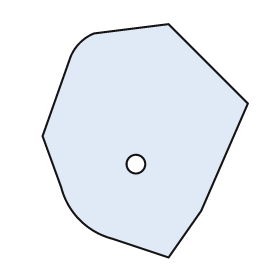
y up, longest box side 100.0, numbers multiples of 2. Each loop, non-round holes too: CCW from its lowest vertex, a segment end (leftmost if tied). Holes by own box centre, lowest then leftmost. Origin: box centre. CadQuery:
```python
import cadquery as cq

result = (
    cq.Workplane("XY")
    .moveTo(10.0, -50.0)
    .lineTo(24.0, -30.0)
    .lineTo(44.0, 16.0)
    .lineTo(10.0, 50.0)
    .lineTo(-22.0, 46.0)
    .threePointArc((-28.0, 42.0), (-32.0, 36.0))
    .lineTo(-44.0, 2.0)
    .lineTo(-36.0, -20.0)
    .threePointArc((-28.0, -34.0), (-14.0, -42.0))
    .close()
    .moveTo(-4.0, -10.0)
    .circle(4.0)
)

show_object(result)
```